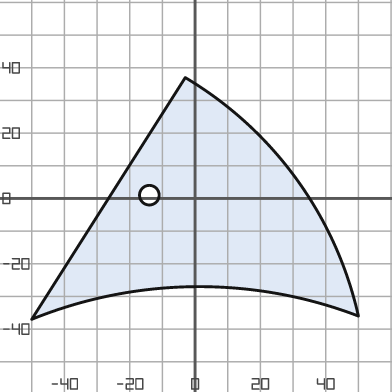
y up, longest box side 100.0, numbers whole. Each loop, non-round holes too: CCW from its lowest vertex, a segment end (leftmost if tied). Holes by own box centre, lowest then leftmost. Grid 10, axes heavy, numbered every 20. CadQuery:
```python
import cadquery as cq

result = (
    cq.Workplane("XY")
    .moveTo(-50.0, -37.0)
    .threePointArc((0.0, -27.0), (50.0, -36.0))
    .threePointArc((31.0, 6.0), (-3.0, 37.0))
    .close()
    .moveTo(-14.0, 1.0)
    .circle(3.0)
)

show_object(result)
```